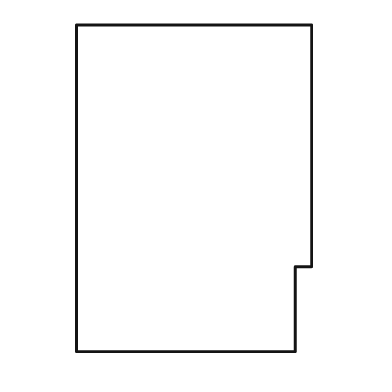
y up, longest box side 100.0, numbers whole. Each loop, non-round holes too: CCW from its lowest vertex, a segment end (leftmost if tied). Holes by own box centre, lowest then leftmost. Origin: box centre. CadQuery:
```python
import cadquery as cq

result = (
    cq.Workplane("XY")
    .moveTo(-36.0, -50.0)
    .lineTo(31.0, -50.0)
    .lineTo(31.0, -24.0)
    .lineTo(36.0, -24.0)
    .lineTo(36.0, 50.0)
    .lineTo(-36.0, 50.0)
    .close()
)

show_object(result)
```